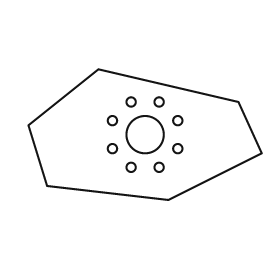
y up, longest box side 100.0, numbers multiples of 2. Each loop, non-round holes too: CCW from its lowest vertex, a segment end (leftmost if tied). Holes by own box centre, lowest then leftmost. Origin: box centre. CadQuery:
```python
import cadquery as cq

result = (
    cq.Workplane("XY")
    .moveTo(10.0, -28.0)
    .lineTo(50.0, -8.0)
    .lineTo(40.0, 14.0)
    .lineTo(-20.0, 28.0)
    .lineTo(-50.0, 4.0)
    .lineTo(-42.0, -22.0)
    .close()
    .moveTo(-6.0, -14.0)
    .circle(2.0)
    .moveTo(6.0, -14.0)
    .circle(2.0)
    .moveTo(-14.0, -6.0)
    .circle(2.0)
    .moveTo(14.0, -6.0)
    .circle(2.0)
    .moveTo(0.0, 0.0)
    .circle(8.0)
    .moveTo(-14.0, 6.0)
    .circle(2.0)
    .moveTo(14.0, 6.0)
    .circle(2.0)
    .moveTo(-6.0, 14.0)
    .circle(2.0)
    .moveTo(6.0, 14.0)
    .circle(2.0)
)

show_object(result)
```